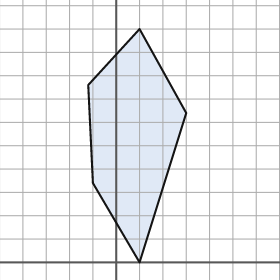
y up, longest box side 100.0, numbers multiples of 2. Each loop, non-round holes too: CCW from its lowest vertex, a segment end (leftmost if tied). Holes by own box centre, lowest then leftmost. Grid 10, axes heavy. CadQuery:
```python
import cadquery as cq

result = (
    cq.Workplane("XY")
    .moveTo(10.0, 0.0)
    .lineTo(30.0, 64.0)
    .lineTo(10.0, 100.0)
    .lineTo(-12.0, 76.0)
    .lineTo(-10.0, 34.0)
    .close()
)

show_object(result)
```